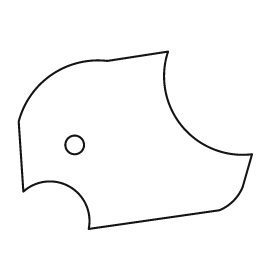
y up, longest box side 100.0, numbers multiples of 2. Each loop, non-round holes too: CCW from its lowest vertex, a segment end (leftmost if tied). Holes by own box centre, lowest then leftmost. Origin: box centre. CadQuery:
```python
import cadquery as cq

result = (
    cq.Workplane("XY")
    .moveTo(-20.0, -38.0)
    .lineTo(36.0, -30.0)
    .threePointArc((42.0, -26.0), (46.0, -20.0))
    .lineTo(50.0, -6.0)
    .threePointArc((20.0, 6.0), (14.0, 38.0))
    .lineTo(-12.0, 34.0)
    .threePointArc((-36.0, 28.0), (-50.0, 8.0))
    .lineTo(-48.0, -22.0)
    .threePointArc((-28.0, -20.0), (-20.0, -38.0))
    .close()
    .moveTo(-26.0, -2.0)
    .circle(4.0)
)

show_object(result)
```